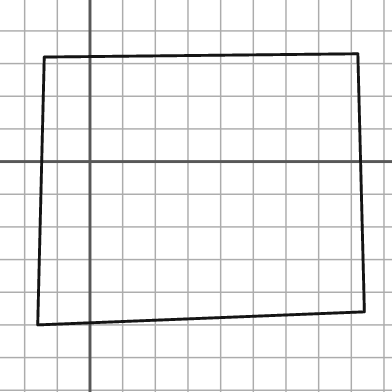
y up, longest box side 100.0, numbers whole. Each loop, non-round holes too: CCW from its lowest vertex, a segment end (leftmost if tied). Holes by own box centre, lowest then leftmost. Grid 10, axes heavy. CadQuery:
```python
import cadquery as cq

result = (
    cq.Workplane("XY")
    .moveTo(-16.0, -50.0)
    .lineTo(84.0, -46.0)
    .lineTo(82.0, 33.0)
    .lineTo(-14.0, 32.0)
    .close()
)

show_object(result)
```